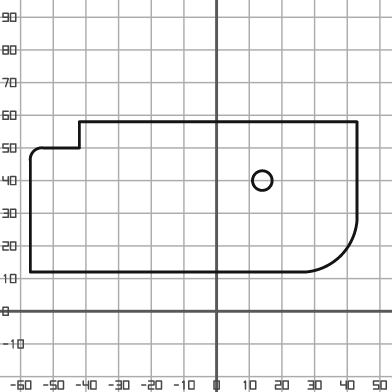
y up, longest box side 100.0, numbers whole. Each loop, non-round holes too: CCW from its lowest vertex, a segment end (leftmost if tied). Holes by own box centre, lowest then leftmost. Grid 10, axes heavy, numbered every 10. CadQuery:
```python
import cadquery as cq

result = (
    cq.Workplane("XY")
    .moveTo(-57.0, 12.0)
    .lineTo(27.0, 12.0)
    .threePointArc((38.0, 17.0), (43.0, 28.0))
    .lineTo(43.0, 58.0)
    .lineTo(-42.0, 58.0)
    .lineTo(-42.0, 50.0)
    .lineTo(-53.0, 50.0)
    .threePointArc((-56.0, 49.0), (-57.0, 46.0))
    .close()
    .moveTo(14.0, 40.0)
    .circle(3.0)
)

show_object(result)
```